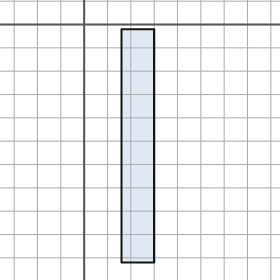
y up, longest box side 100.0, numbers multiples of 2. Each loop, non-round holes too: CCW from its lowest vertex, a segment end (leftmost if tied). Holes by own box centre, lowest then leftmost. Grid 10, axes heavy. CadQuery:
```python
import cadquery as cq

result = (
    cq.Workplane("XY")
    .moveTo(16.0, -102.0)
    .lineTo(30.0, -102.0)
    .lineTo(30.0, -2.0)
    .lineTo(16.0, -2.0)
    .close()
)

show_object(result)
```